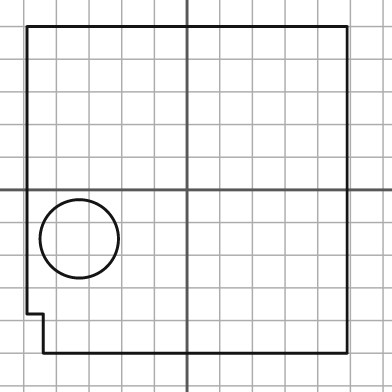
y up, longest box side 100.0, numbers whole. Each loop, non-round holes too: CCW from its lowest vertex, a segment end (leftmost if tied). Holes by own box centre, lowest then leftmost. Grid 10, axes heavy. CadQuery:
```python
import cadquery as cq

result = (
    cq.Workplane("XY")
    .moveTo(-44.0, -50.0)
    .lineTo(49.0, -50.0)
    .lineTo(49.0, 50.0)
    .lineTo(-49.0, 50.0)
    .lineTo(-49.0, -38.0)
    .lineTo(-44.0, -38.0)
    .close()
    .moveTo(-33.0, -15.0)
    .circle(12.0)
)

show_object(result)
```